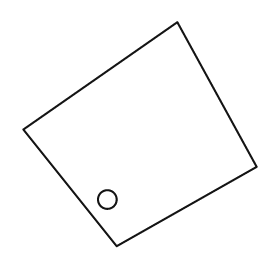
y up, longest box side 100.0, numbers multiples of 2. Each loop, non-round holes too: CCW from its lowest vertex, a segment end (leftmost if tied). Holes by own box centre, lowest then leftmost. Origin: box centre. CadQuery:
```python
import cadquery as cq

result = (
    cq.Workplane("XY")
    .moveTo(-10.0, -48.0)
    .lineTo(50.0, -14.0)
    .lineTo(16.0, 48.0)
    .lineTo(-50.0, 2.0)
    .close()
    .moveTo(-14.0, -28.0)
    .circle(4.0)
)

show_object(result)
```